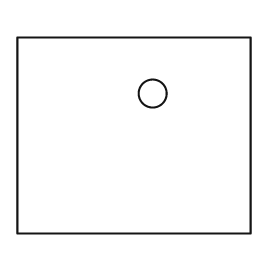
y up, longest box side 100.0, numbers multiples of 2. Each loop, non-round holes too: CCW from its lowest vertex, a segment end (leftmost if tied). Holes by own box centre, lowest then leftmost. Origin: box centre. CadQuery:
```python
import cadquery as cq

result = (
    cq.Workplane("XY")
    .moveTo(-50.0, -42.0)
    .lineTo(50.0, -42.0)
    .lineTo(50.0, 42.0)
    .lineTo(-50.0, 42.0)
    .close()
    .moveTo(8.0, 18.0)
    .circle(6.0)
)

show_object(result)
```